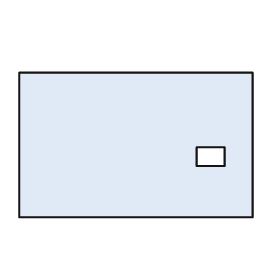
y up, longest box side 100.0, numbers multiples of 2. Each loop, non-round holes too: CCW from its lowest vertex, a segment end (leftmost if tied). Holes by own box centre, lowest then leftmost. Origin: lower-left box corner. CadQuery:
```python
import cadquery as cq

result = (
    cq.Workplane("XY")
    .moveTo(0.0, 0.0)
    .lineTo(100.0, 0.0)
    .lineTo(100.0, 62.0)
    .lineTo(0.0, 62.0)
    .close()
    .moveTo(76.0, 22.0)
    .lineTo(88.0, 22.0)
    .lineTo(88.0, 30.0)
    .lineTo(76.0, 30.0)
    .close()
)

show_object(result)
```